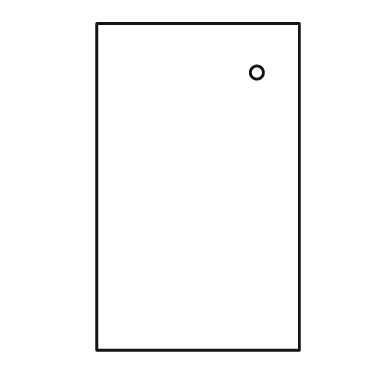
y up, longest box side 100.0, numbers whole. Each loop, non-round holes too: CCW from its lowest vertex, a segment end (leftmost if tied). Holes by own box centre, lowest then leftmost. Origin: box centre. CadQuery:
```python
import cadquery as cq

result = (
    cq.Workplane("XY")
    .moveTo(-31.0, -50.0)
    .lineTo(31.0, -50.0)
    .lineTo(31.0, 50.0)
    .lineTo(-31.0, 50.0)
    .close()
    .moveTo(18.0, 35.0)
    .circle(2.0)
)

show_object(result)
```